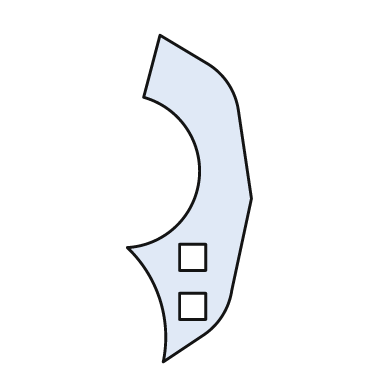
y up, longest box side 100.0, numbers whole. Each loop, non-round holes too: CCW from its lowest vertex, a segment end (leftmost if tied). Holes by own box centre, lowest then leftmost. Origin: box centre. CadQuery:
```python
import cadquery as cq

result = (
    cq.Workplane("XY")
    .moveTo(-8.0, -50.0)
    .lineTo(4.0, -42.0)
    .threePointArc((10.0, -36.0), (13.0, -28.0))
    .lineTo(19.0, 0.0)
    .lineTo(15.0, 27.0)
    .threePointArc((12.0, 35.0), (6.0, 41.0))
    .lineTo(-9.0, 50.0)
    .lineTo(-14.0, 31.0)
    .threePointArc((3.0, 6.0), (-19.0, -15.0))
    .threePointArc((-9.0, -31.0), (-8.0, -50.0))
    .close()
    .moveTo(-3.0, -37.0)
    .lineTo(5.0, -37.0)
    .lineTo(5.0, -29.0)
    .lineTo(-3.0, -29.0)
    .close()
    .moveTo(-3.0, -22.0)
    .lineTo(5.0, -22.0)
    .lineTo(5.0, -14.0)
    .lineTo(-3.0, -14.0)
    .close()
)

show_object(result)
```